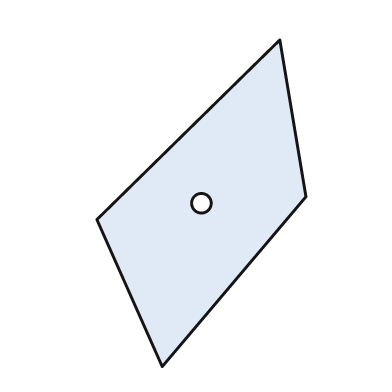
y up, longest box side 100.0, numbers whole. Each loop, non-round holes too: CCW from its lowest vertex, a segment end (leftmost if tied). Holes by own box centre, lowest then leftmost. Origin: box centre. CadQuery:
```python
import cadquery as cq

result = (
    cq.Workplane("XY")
    .moveTo(-12.0, -50.0)
    .lineTo(32.0, 2.0)
    .lineTo(24.0, 50.0)
    .lineTo(-32.0, -5.0)
    .close()
    .moveTo(0.0, 0.0)
    .circle(3.0)
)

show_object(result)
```